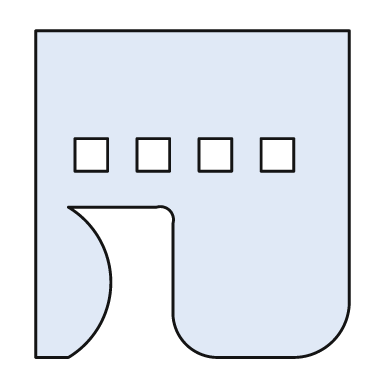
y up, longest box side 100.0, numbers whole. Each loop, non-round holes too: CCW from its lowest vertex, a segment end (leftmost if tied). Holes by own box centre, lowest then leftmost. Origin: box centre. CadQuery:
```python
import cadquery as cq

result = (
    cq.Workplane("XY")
    .moveTo(-48.0, -50.0)
    .lineTo(-38.0, -50.0)
    .threePointArc((-25.0, -27.0), (-38.0, -4.0))
    .lineTo(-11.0, -4.0)
    .threePointArc((-7.0, -5.0), (-6.0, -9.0))
    .lineTo(-6.0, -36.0)
    .threePointArc((-2.0, -46.0), (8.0, -50.0))
    .lineTo(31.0, -50.0)
    .threePointArc((43.0, -45.0), (48.0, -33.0))
    .lineTo(48.0, 50.0)
    .lineTo(-48.0, 50.0)
    .close()
    .moveTo(-36.0, 7.0)
    .lineTo(-26.0, 7.0)
    .lineTo(-26.0, 17.0)
    .lineTo(-36.0, 17.0)
    .close()
    .moveTo(-17.0, 7.0)
    .lineTo(-7.0, 7.0)
    .lineTo(-7.0, 17.0)
    .lineTo(-17.0, 17.0)
    .close()
    .moveTo(2.0, 7.0)
    .lineTo(12.0, 7.0)
    .lineTo(12.0, 17.0)
    .lineTo(2.0, 17.0)
    .close()
    .moveTo(21.0, 7.0)
    .lineTo(31.0, 7.0)
    .lineTo(31.0, 17.0)
    .lineTo(21.0, 17.0)
    .close()
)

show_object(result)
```